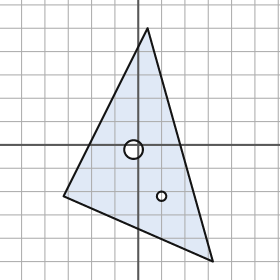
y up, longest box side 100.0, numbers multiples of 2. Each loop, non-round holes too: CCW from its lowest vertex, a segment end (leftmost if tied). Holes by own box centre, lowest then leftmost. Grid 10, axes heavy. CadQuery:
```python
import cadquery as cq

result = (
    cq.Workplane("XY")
    .moveTo(32.0, -50.0)
    .lineTo(4.0, 50.0)
    .lineTo(-32.0, -22.0)
    .close()
    .moveTo(10.0, -22.0)
    .circle(2.0)
    .moveTo(-2.0, -2.0)
    .circle(4.0)
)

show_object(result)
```